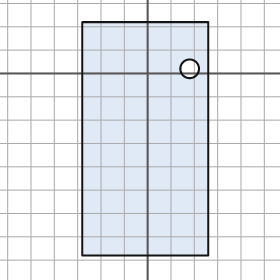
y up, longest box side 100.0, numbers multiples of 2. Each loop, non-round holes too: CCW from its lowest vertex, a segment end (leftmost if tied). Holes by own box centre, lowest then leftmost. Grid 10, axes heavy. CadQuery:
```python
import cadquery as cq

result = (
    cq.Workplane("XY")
    .moveTo(-28.0, -78.0)
    .lineTo(26.0, -78.0)
    .lineTo(26.0, 22.0)
    .lineTo(-28.0, 22.0)
    .close()
    .moveTo(18.0, 2.0)
    .circle(4.0)
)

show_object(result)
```